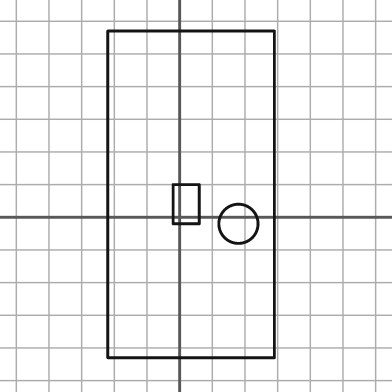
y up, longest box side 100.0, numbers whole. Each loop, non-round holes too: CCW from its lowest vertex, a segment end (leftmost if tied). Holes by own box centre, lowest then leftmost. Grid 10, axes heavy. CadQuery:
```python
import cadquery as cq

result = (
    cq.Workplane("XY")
    .moveTo(-22.0, -43.0)
    .lineTo(29.0, -43.0)
    .lineTo(29.0, 57.0)
    .lineTo(-22.0, 57.0)
    .close()
    .moveTo(18.0, -2.0)
    .circle(6.0)
    .moveTo(-2.0, -2.0)
    .lineTo(6.0, -2.0)
    .lineTo(6.0, 10.0)
    .lineTo(-2.0, 10.0)
    .close()
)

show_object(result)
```